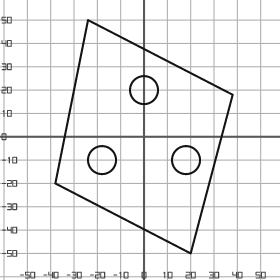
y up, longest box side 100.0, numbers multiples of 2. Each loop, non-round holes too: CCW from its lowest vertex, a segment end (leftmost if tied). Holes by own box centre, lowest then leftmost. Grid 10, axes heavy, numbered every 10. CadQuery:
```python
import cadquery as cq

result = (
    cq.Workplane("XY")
    .moveTo(20.0, -50.0)
    .lineTo(38.0, 18.0)
    .lineTo(-24.0, 50.0)
    .lineTo(-38.0, -20.0)
    .close()
    .moveTo(-18.0, -10.0)
    .circle(6.0)
    .moveTo(18.0, -10.0)
    .circle(6.0)
    .moveTo(0.0, 20.0)
    .circle(6.0)
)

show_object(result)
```